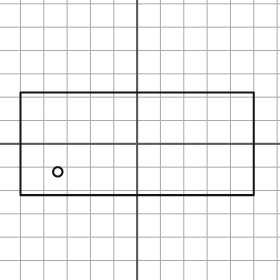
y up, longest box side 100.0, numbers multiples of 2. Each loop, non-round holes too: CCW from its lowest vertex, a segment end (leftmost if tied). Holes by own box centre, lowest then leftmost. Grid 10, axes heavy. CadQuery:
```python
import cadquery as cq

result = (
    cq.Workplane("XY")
    .moveTo(-50.0, -22.0)
    .lineTo(50.0, -22.0)
    .lineTo(50.0, 22.0)
    .lineTo(-50.0, 22.0)
    .close()
    .moveTo(-34.0, -12.0)
    .circle(2.0)
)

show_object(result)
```